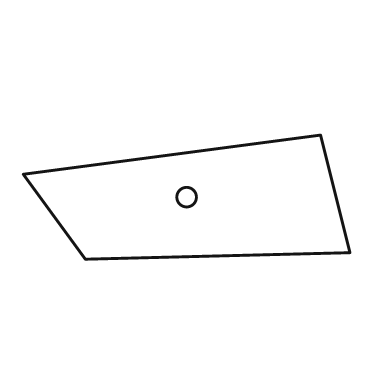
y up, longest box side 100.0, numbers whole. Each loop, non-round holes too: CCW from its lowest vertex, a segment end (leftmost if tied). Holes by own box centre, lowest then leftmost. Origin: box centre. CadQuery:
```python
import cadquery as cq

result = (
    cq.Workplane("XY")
    .moveTo(-31.0, -19.0)
    .lineTo(50.0, -17.0)
    .lineTo(41.0, 19.0)
    .lineTo(-50.0, 7.0)
    .close()
    .moveTo(0.0, 0.0)
    .circle(3.0)
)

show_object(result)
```